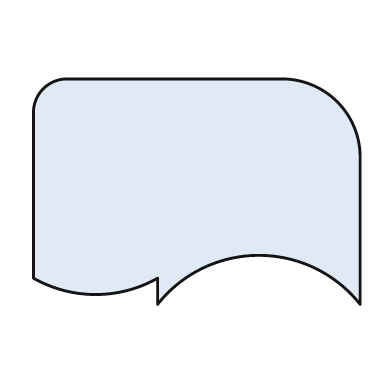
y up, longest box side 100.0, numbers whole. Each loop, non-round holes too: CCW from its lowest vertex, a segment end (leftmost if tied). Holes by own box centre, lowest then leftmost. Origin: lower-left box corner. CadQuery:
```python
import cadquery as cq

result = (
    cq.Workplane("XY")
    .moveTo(38.0, 0.0)
    .threePointArc((69.0, 15.0), (100.0, 0.0))
    .lineTo(100.0, 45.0)
    .threePointArc((93.0, 62.0), (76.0, 69.0))
    .lineTo(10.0, 69.0)
    .threePointArc((3.0, 66.0), (0.0, 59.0))
    .lineTo(0.0, 8.0)
    .threePointArc((19.0, 3.0), (38.0, 8.0))
    .close()
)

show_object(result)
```